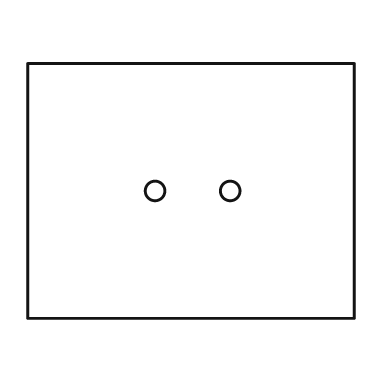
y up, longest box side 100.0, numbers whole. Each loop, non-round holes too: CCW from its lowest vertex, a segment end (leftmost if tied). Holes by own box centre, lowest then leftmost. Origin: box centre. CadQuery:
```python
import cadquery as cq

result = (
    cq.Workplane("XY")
    .moveTo(-50.0, -39.0)
    .lineTo(50.0, -39.0)
    .lineTo(50.0, 39.0)
    .lineTo(-50.0, 39.0)
    .close()
    .moveTo(-11.0, 0.0)
    .circle(3.0)
    .moveTo(12.0, 0.0)
    .circle(3.0)
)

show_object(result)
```